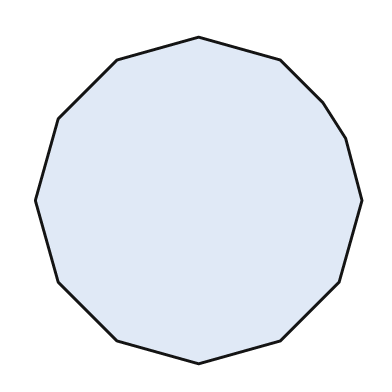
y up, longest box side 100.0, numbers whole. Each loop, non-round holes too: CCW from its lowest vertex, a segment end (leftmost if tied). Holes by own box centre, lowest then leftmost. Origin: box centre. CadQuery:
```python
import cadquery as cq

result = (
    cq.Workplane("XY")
    .moveTo(0.0, -50.0)
    .lineTo(25.0, -43.0)
    .lineTo(43.0, -25.0)
    .lineTo(50.0, 0.0)
    .lineTo(45.0, 19.0)
    .lineTo(38.0, 30.0)
    .lineTo(25.0, 43.0)
    .lineTo(0.0, 50.0)
    .lineTo(-25.0, 43.0)
    .lineTo(-43.0, 25.0)
    .lineTo(-50.0, 0.0)
    .lineTo(-43.0, -25.0)
    .lineTo(-25.0, -43.0)
    .close()
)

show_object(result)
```